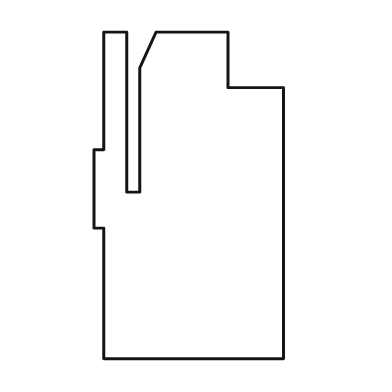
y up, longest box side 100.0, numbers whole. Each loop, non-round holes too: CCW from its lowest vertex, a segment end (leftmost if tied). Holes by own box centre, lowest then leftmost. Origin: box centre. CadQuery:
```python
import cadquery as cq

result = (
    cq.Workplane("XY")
    .moveTo(-26.0, -50.0)
    .lineTo(29.0, -50.0)
    .lineTo(29.0, 33.0)
    .lineTo(12.0, 33.0)
    .lineTo(12.0, 50.0)
    .lineTo(-10.0, 50.0)
    .lineTo(-15.0, 39.0)
    .lineTo(-15.0, 1.0)
    .lineTo(-19.0, 1.0)
    .lineTo(-19.0, 50.0)
    .lineTo(-26.0, 50.0)
    .lineTo(-26.0, 14.0)
    .lineTo(-29.0, 14.0)
    .lineTo(-29.0, -10.0)
    .lineTo(-26.0, -10.0)
    .close()
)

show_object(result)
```